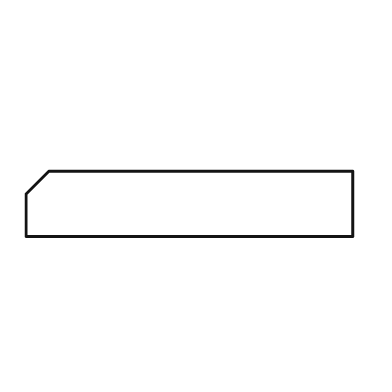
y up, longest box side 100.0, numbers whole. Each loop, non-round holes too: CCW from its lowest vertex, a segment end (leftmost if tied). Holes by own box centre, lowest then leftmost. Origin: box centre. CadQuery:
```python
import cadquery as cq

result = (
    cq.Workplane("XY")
    .moveTo(-50.0, -10.0)
    .lineTo(50.0, -10.0)
    .lineTo(50.0, 10.0)
    .lineTo(-43.0, 10.0)
    .lineTo(-50.0, 3.0)
    .close()
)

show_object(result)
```